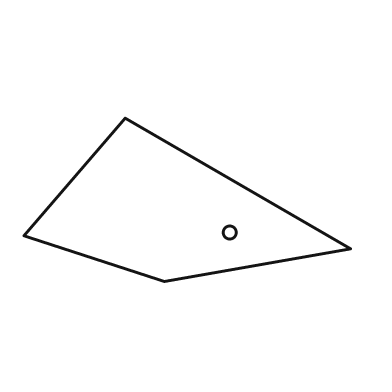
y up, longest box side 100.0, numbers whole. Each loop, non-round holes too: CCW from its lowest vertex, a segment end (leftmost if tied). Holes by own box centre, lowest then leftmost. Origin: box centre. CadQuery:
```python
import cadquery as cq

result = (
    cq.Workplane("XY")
    .moveTo(-7.0, -25.0)
    .lineTo(50.0, -15.0)
    .lineTo(-19.0, 25.0)
    .lineTo(-50.0, -11.0)
    .close()
    .moveTo(13.0, -10.0)
    .circle(2.0)
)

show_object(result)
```